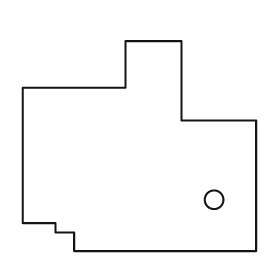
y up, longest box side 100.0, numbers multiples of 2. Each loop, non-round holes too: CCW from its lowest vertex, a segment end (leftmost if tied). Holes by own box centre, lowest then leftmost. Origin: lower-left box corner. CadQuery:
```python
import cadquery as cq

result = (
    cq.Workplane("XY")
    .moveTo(22.0, 0.0)
    .lineTo(100.0, 0.0)
    .lineTo(100.0, 56.0)
    .lineTo(68.0, 56.0)
    .lineTo(68.0, 90.0)
    .lineTo(44.0, 90.0)
    .lineTo(44.0, 70.0)
    .lineTo(0.0, 70.0)
    .lineTo(0.0, 12.0)
    .lineTo(14.0, 12.0)
    .lineTo(14.0, 8.0)
    .lineTo(22.0, 8.0)
    .close()
    .moveTo(82.0, 22.0)
    .circle(4.0)
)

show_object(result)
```